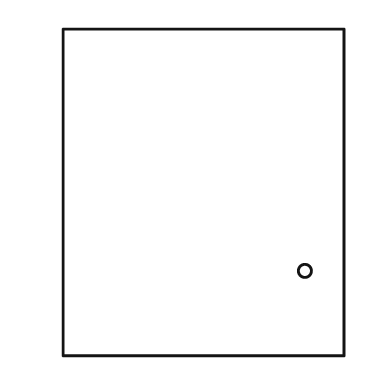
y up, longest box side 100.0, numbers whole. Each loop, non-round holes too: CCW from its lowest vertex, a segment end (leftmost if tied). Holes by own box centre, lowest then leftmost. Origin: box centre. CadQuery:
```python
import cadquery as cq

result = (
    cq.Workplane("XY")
    .moveTo(-43.0, -50.0)
    .lineTo(43.0, -50.0)
    .lineTo(43.0, 50.0)
    .lineTo(-43.0, 50.0)
    .close()
    .moveTo(31.0, -24.0)
    .circle(2.0)
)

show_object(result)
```